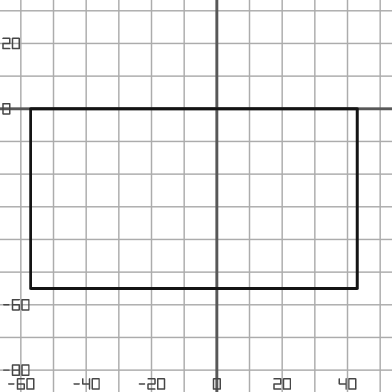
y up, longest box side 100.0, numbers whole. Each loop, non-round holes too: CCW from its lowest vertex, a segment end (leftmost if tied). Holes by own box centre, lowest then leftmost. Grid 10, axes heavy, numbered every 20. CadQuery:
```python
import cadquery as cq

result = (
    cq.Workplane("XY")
    .moveTo(-57.0, -55.0)
    .lineTo(43.0, -55.0)
    .lineTo(43.0, 0.0)
    .lineTo(-57.0, 0.0)
    .close()
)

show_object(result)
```